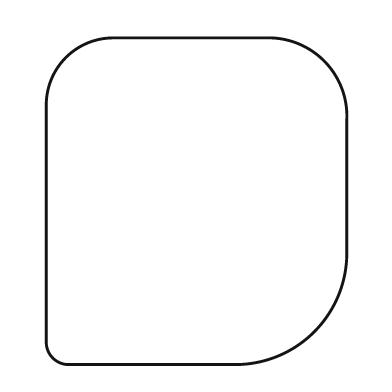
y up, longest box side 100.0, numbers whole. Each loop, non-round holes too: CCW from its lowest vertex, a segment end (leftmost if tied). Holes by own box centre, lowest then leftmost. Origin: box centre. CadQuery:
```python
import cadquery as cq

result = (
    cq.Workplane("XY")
    .moveTo(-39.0, -50.0)
    .lineTo(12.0, -50.0)
    .threePointArc((36.0, -40.0), (46.0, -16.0))
    .lineTo(46.0, 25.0)
    .threePointArc((39.0, 43.0), (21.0, 50.0))
    .lineTo(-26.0, 50.0)
    .threePointArc((-40.0, 44.0), (-46.0, 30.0))
    .lineTo(-46.0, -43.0)
    .threePointArc((-44.0, -48.0), (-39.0, -50.0))
    .close()
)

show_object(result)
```